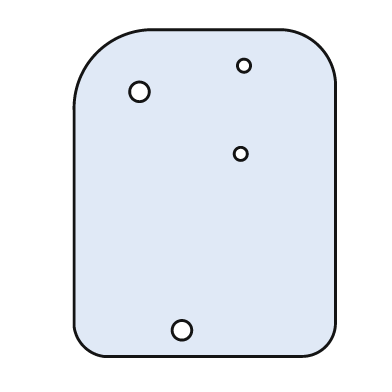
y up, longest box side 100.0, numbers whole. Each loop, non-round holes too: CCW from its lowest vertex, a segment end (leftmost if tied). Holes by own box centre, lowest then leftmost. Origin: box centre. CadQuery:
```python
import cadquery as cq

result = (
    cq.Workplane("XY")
    .moveTo(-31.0, -50.0)
    .lineTo(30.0, -50.0)
    .threePointArc((37.0, -47.0), (40.0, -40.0))
    .lineTo(40.0, 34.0)
    .threePointArc((35.0, 45.0), (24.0, 50.0))
    .lineTo(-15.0, 50.0)
    .threePointArc((-33.0, 43.0), (-40.0, 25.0))
    .lineTo(-40.0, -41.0)
    .threePointArc((-37.0, -47.0), (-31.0, -50.0))
    .close()
    .moveTo(-7.0, -42.0)
    .circle(3.0)
    .moveTo(11.0, 12.0)
    .circle(2.0)
    .moveTo(-20.0, 31.0)
    .circle(3.0)
    .moveTo(12.0, 39.0)
    .circle(2.0)
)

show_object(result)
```